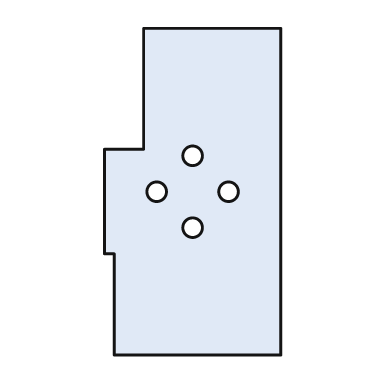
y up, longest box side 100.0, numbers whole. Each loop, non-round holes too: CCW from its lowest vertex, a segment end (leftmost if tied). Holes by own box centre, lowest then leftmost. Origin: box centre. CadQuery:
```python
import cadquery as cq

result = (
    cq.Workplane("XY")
    .moveTo(-24.0, -50.0)
    .lineTo(27.0, -50.0)
    .lineTo(27.0, 50.0)
    .lineTo(-15.0, 50.0)
    .lineTo(-15.0, 13.0)
    .lineTo(-27.0, 13.0)
    .lineTo(-27.0, -19.0)
    .lineTo(-24.0, -19.0)
    .close()
    .moveTo(0.0, -11.0)
    .circle(3.0)
    .moveTo(-11.0, 0.0)
    .circle(3.0)
    .moveTo(11.0, 0.0)
    .circle(3.0)
    .moveTo(0.0, 11.0)
    .circle(3.0)
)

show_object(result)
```